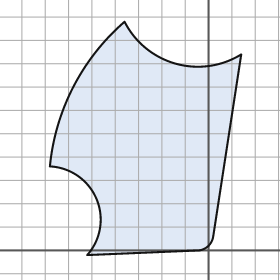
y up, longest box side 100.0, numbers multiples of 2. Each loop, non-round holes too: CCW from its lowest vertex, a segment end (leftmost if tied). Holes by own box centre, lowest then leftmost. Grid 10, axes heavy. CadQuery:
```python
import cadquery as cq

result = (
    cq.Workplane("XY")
    .moveTo(-52.0, -2.0)
    .lineTo(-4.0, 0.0)
    .threePointArc((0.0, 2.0), (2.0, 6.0))
    .lineTo(14.0, 84.0)
    .threePointArc((-14.0, 80.0), (-36.0, 98.0))
    .threePointArc((-58.0, 70.0), (-68.0, 36.0))
    .threePointArc((-48.0, 22.0), (-52.0, -2.0))
    .close()
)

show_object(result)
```